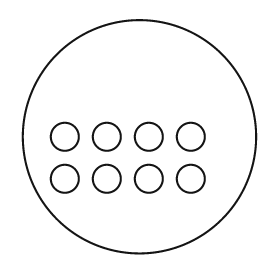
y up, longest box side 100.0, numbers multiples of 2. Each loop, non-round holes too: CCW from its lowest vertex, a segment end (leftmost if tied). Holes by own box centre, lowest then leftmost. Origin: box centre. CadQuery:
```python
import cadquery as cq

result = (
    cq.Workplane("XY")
    .moveTo(0.0, 0.0)
    .circle(50.0)
    .moveTo(-32.0, -18.0)
    .circle(6.0)
    .moveTo(-14.0, -18.0)
    .circle(6.0)
    .moveTo(4.0, -18.0)
    .circle(6.0)
    .moveTo(22.0, -18.0)
    .circle(6.0)
    .moveTo(-32.0, 0.0)
    .circle(6.0)
    .moveTo(-14.0, 0.0)
    .circle(6.0)
    .moveTo(4.0, 0.0)
    .circle(6.0)
    .moveTo(22.0, 0.0)
    .circle(6.0)
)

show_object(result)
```